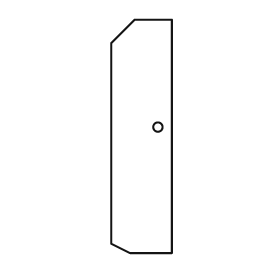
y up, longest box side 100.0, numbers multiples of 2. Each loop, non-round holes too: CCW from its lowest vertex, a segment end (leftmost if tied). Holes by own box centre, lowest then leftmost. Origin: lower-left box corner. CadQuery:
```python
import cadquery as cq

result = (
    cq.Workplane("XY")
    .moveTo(8.0, 0.0)
    .lineTo(26.0, 0.0)
    .lineTo(26.0, 100.0)
    .lineTo(10.0, 100.0)
    .lineTo(0.0, 90.0)
    .lineTo(0.0, 4.0)
    .close()
    .moveTo(20.0, 54.0)
    .circle(2.0)
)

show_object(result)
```